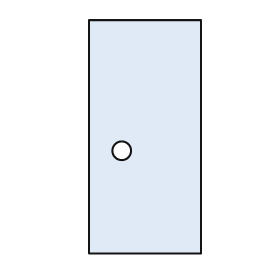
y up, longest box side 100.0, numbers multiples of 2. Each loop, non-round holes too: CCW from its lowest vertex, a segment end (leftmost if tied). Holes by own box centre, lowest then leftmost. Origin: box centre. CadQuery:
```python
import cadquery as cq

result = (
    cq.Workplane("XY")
    .moveTo(-24.0, -50.0)
    .lineTo(24.0, -50.0)
    .lineTo(24.0, 50.0)
    .lineTo(-24.0, 50.0)
    .close()
    .moveTo(-10.0, -6.0)
    .circle(4.0)
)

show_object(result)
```